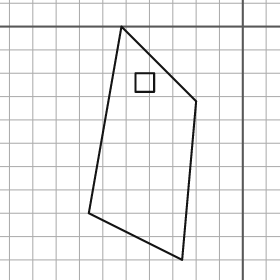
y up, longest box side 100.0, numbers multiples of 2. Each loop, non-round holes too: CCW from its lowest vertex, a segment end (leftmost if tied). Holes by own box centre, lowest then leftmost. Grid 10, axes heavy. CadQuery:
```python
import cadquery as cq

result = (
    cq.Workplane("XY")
    .moveTo(-26.0, -100.0)
    .lineTo(-20.0, -32.0)
    .lineTo(-52.0, 0.0)
    .lineTo(-66.0, -80.0)
    .close()
    .moveTo(-46.0, -28.0)
    .lineTo(-38.0, -28.0)
    .lineTo(-38.0, -20.0)
    .lineTo(-46.0, -20.0)
    .close()
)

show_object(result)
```